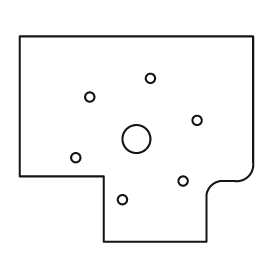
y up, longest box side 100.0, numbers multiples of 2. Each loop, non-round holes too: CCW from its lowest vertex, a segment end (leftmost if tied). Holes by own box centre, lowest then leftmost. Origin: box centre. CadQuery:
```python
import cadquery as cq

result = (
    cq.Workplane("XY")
    .moveTo(-14.0, -44.0)
    .lineTo(30.0, -44.0)
    .lineTo(30.0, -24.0)
    .threePointArc((32.0, -20.0), (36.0, -18.0))
    .lineTo(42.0, -18.0)
    .threePointArc((48.0, -16.0), (50.0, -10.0))
    .lineTo(50.0, 44.0)
    .lineTo(-50.0, 44.0)
    .lineTo(-50.0, -16.0)
    .lineTo(-14.0, -16.0)
    .close()
    .moveTo(-6.0, -26.0)
    .circle(2.0)
    .moveTo(20.0, -18.0)
    .circle(2.0)
    .moveTo(-26.0, -8.0)
    .circle(2.0)
    .moveTo(0.0, 0.0)
    .circle(6.0)
    .moveTo(26.0, 8.0)
    .circle(2.0)
    .moveTo(-20.0, 18.0)
    .circle(2.0)
    .moveTo(6.0, 26.0)
    .circle(2.0)
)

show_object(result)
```